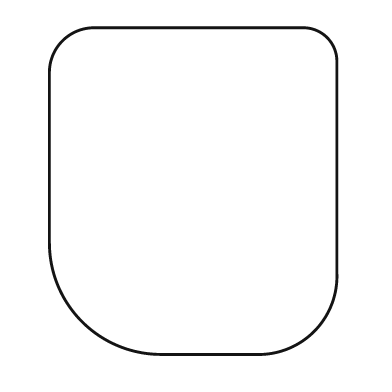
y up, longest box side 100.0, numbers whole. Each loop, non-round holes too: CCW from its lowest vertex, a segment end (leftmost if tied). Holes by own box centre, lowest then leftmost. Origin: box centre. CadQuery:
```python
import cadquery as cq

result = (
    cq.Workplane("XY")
    .moveTo(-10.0, -50.0)
    .lineTo(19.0, -50.0)
    .threePointArc((37.0, -43.0), (44.0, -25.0))
    .lineTo(44.0, 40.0)
    .threePointArc((41.0, 47.0), (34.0, 50.0))
    .lineTo(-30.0, 50.0)
    .threePointArc((-40.0, 46.0), (-44.0, 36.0))
    .lineTo(-44.0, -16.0)
    .threePointArc((-34.0, -40.0), (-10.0, -50.0))
    .close()
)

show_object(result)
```